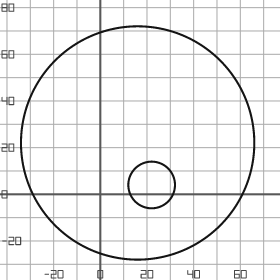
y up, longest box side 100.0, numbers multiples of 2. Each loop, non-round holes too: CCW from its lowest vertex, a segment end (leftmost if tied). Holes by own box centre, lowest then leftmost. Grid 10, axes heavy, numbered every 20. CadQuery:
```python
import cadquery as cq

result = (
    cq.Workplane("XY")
    .moveTo(16.0, 22.0)
    .circle(50.0)
    .moveTo(22.0, 4.0)
    .circle(10.0)
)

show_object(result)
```